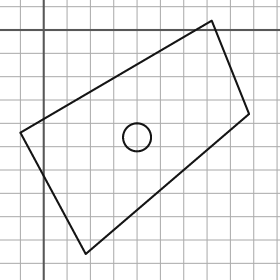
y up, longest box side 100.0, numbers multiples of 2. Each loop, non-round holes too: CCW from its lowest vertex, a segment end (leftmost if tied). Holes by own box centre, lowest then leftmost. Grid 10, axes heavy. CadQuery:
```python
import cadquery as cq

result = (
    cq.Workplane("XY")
    .moveTo(18.0, -96.0)
    .lineTo(88.0, -36.0)
    .lineTo(72.0, 4.0)
    .lineTo(-10.0, -44.0)
    .close()
    .moveTo(40.0, -46.0)
    .circle(6.0)
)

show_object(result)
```